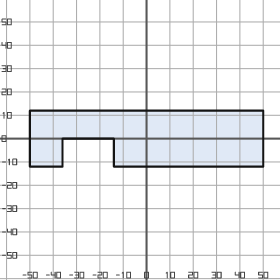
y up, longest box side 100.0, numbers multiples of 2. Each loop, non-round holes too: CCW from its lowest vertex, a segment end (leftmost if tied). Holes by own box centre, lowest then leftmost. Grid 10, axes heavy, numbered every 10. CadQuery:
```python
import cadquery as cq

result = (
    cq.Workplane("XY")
    .moveTo(-50.0, -12.0)
    .lineTo(-36.0, -12.0)
    .lineTo(-36.0, 0.0)
    .lineTo(-14.0, 0.0)
    .lineTo(-14.0, -12.0)
    .lineTo(50.0, -12.0)
    .lineTo(50.0, 12.0)
    .lineTo(-50.0, 12.0)
    .close()
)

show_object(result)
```